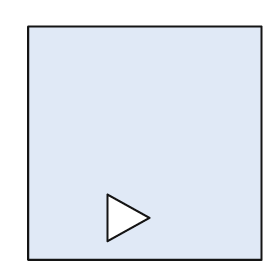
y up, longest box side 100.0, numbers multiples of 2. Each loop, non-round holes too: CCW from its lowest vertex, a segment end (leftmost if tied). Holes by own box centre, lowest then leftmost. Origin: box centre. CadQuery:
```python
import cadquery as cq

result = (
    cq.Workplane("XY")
    .moveTo(-50.0, -50.0)
    .lineTo(50.0, -50.0)
    .lineTo(50.0, 50.0)
    .lineTo(-50.0, 50.0)
    .close()
    .moveTo(-16.0, -42.0)
    .lineTo(2.0, -32.0)
    .lineTo(-16.0, -22.0)
    .close()
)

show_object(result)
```